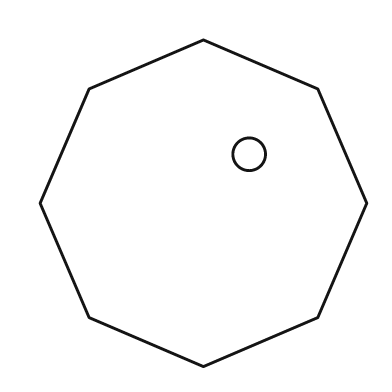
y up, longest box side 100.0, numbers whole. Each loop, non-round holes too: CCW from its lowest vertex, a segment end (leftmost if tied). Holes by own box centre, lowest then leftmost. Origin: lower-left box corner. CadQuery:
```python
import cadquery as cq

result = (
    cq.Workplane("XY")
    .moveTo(50.0, 0.0)
    .lineTo(85.0, 15.0)
    .lineTo(100.0, 50.0)
    .lineTo(85.0, 85.0)
    .lineTo(50.0, 100.0)
    .lineTo(15.0, 85.0)
    .lineTo(0.0, 50.0)
    .lineTo(15.0, 15.0)
    .close()
    .moveTo(64.0, 65.0)
    .circle(5.0)
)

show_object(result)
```